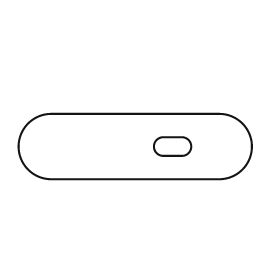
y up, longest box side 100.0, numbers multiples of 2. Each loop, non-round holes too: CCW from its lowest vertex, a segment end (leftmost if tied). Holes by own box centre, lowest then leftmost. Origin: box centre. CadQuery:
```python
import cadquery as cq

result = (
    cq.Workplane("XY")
    .moveTo(-36.0, -14.0)
    .lineTo(36.0, -14.0)
    .threePointArc((50.0, 0.0), (36.0, 14.0))
    .lineTo(-36.0, 14.0)
    .threePointArc((-50.0, 0.0), (-36.0, -14.0))
    .close()
    .moveTo(12.0, -4.0)
    .lineTo(20.0, -4.0)
    .threePointArc((24.0, 0.0), (20.0, 4.0))
    .lineTo(12.0, 4.0)
    .threePointArc((8.0, 0.0), (12.0, -4.0))
    .close()
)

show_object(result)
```